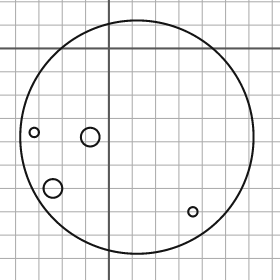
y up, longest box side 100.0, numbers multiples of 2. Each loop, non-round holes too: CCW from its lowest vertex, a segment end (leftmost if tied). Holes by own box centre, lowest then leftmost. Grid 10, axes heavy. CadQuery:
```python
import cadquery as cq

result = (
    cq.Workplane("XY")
    .moveTo(12.0, -38.0)
    .circle(50.0)
    .moveTo(36.0, -70.0)
    .circle(2.0)
    .moveTo(-24.0, -60.0)
    .circle(4.0)
    .moveTo(-8.0, -38.0)
    .circle(4.0)
    .moveTo(-32.0, -36.0)
    .circle(2.0)
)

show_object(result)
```